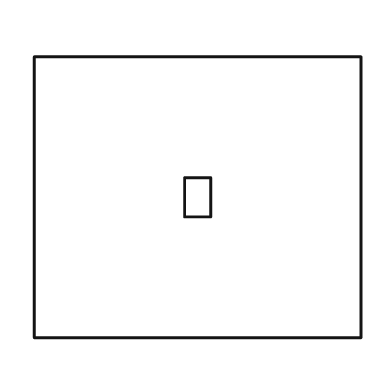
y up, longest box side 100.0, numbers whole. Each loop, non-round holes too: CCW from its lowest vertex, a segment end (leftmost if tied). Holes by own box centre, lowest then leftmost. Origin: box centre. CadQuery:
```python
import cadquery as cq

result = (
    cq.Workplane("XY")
    .moveTo(-50.0, -43.0)
    .lineTo(50.0, -43.0)
    .lineTo(50.0, 43.0)
    .lineTo(-50.0, 43.0)
    .close()
    .moveTo(-4.0, -6.0)
    .lineTo(4.0, -6.0)
    .lineTo(4.0, 6.0)
    .lineTo(-4.0, 6.0)
    .close()
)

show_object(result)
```